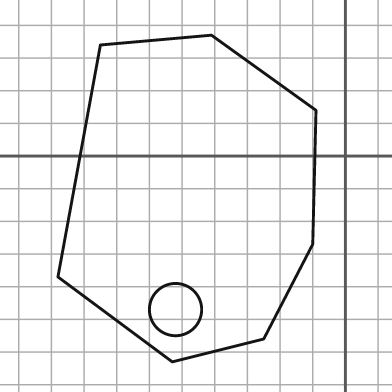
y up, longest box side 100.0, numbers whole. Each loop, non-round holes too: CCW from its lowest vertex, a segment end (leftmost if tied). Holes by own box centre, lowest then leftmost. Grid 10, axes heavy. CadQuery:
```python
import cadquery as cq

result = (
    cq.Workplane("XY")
    .moveTo(-53.0, -63.0)
    .lineTo(-25.0, -56.0)
    .lineTo(-10.0, -27.0)
    .lineTo(-9.0, 14.0)
    .lineTo(-41.0, 37.0)
    .lineTo(-75.0, 34.0)
    .lineTo(-88.0, -37.0)
    .close()
    .moveTo(-52.0, -47.0)
    .circle(8.0)
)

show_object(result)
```